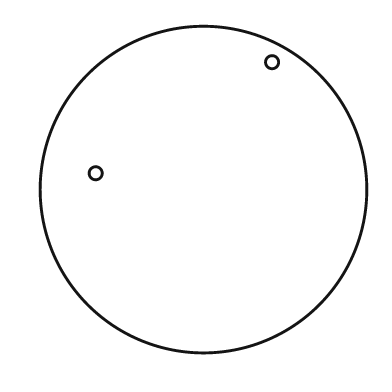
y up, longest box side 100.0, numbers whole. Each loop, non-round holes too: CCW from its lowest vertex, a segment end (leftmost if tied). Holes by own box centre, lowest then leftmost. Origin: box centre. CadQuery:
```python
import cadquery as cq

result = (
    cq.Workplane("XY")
    .moveTo(0.0, 0.0)
    .circle(50.0)
    .moveTo(-33.0, 5.0)
    .circle(2.0)
    .moveTo(21.0, 39.0)
    .circle(2.0)
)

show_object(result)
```